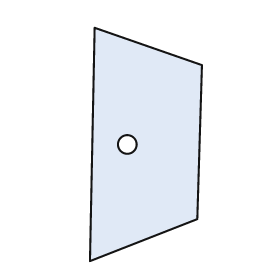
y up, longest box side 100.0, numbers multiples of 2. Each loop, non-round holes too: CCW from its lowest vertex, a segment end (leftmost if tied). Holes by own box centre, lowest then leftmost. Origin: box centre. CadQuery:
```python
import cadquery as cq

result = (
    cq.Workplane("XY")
    .moveTo(-24.0, -50.0)
    .lineTo(22.0, -32.0)
    .lineTo(24.0, 34.0)
    .lineTo(-22.0, 50.0)
    .close()
    .moveTo(-8.0, 0.0)
    .circle(4.0)
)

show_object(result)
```